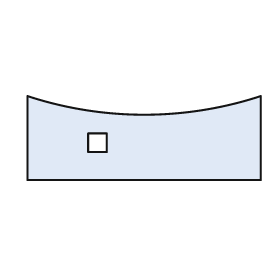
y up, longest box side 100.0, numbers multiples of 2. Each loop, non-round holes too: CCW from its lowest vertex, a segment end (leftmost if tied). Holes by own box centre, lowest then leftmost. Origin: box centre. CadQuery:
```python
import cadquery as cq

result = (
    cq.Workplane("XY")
    .moveTo(-50.0, -18.0)
    .lineTo(50.0, -18.0)
    .lineTo(50.0, 18.0)
    .threePointArc((0.0, 10.0), (-50.0, 18.0))
    .close()
    .moveTo(-24.0, -6.0)
    .lineTo(-16.0, -6.0)
    .lineTo(-16.0, 2.0)
    .lineTo(-24.0, 2.0)
    .close()
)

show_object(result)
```